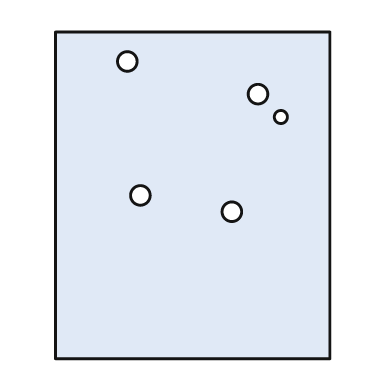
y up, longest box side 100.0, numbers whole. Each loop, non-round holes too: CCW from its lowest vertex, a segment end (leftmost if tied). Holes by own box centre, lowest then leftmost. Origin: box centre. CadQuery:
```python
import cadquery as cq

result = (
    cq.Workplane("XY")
    .moveTo(-42.0, -50.0)
    .lineTo(42.0, -50.0)
    .lineTo(42.0, 50.0)
    .lineTo(-42.0, 50.0)
    .close()
    .moveTo(12.0, -5.0)
    .circle(3.0)
    .moveTo(-16.0, 0.0)
    .circle(3.0)
    .moveTo(27.0, 24.0)
    .circle(2.0)
    .moveTo(20.0, 31.0)
    .circle(3.0)
    .moveTo(-20.0, 41.0)
    .circle(3.0)
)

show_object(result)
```